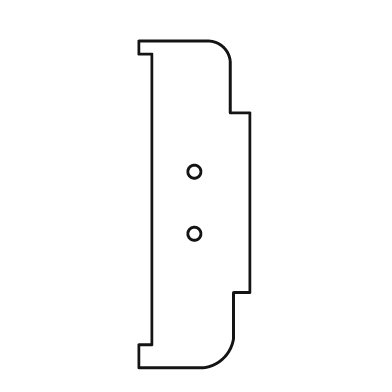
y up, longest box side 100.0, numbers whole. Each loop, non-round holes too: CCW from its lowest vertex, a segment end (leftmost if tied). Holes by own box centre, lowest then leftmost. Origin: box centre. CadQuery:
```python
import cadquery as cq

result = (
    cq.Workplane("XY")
    .moveTo(-17.0, -50.0)
    .lineTo(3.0, -50.0)
    .threePointArc((9.0, -47.0), (12.0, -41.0))
    .lineTo(12.0, -27.0)
    .lineTo(17.0, -27.0)
    .lineTo(17.0, 28.0)
    .lineTo(11.0, 28.0)
    .lineTo(11.0, 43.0)
    .threePointArc((9.0, 48.0), (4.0, 50.0))
    .lineTo(-17.0, 50.0)
    .lineTo(-17.0, 46.0)
    .lineTo(-13.0, 46.0)
    .lineTo(-13.0, -43.0)
    .lineTo(-17.0, -43.0)
    .close()
    .moveTo(0.0, -9.0)
    .circle(2.0)
    .moveTo(0.0, 10.0)
    .circle(2.0)
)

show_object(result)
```